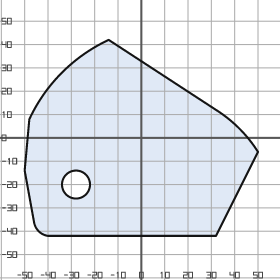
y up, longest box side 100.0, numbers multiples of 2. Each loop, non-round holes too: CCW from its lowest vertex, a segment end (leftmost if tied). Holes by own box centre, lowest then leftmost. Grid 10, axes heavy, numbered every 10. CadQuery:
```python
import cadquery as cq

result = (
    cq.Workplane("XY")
    .moveTo(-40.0, -42.0)
    .lineTo(32.0, -42.0)
    .lineTo(50.0, -6.0)
    .threePointArc((42.0, 4.0), (32.0, 12.0))
    .lineTo(-14.0, 42.0)
    .threePointArc((-34.0, 28.0), (-48.0, 8.0))
    .lineTo(-50.0, -14.0)
    .lineTo(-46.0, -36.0)
    .threePointArc((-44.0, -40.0), (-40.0, -42.0))
    .close()
    .moveTo(-28.0, -20.0)
    .circle(6.0)
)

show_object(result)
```